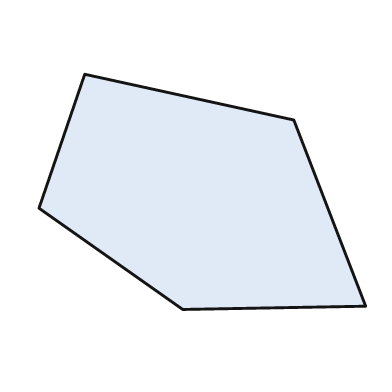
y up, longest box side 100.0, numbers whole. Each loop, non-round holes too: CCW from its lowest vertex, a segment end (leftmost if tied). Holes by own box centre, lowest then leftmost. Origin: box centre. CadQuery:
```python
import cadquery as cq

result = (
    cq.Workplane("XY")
    .moveTo(-6.0, -36.0)
    .lineTo(50.0, -35.0)
    .lineTo(28.0, 22.0)
    .lineTo(-36.0, 36.0)
    .lineTo(-50.0, -5.0)
    .close()
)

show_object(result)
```